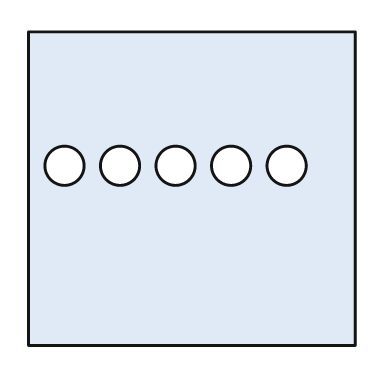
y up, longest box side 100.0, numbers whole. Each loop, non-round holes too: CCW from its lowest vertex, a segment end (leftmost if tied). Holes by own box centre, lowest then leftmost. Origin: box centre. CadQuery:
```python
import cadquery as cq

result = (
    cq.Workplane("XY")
    .moveTo(-50.0, -48.0)
    .lineTo(50.0, -48.0)
    .lineTo(50.0, 48.0)
    .lineTo(-50.0, 48.0)
    .close()
    .moveTo(-39.0, 7.0)
    .circle(6.0)
    .moveTo(-22.0, 7.0)
    .circle(6.0)
    .moveTo(-5.0, 7.0)
    .circle(6.0)
    .moveTo(12.0, 7.0)
    .circle(6.0)
    .moveTo(29.0, 7.0)
    .circle(6.0)
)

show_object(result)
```